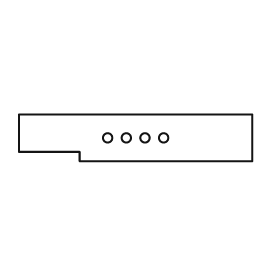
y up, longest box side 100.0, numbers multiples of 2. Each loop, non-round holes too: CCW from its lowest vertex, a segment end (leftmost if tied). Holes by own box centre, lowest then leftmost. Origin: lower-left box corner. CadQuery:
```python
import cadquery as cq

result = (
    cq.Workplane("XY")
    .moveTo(26.0, 0.0)
    .lineTo(100.0, 0.0)
    .lineTo(100.0, 20.0)
    .lineTo(0.0, 20.0)
    .lineTo(0.0, 4.0)
    .lineTo(26.0, 4.0)
    .close()
    .moveTo(38.0, 10.0)
    .circle(2.0)
    .moveTo(46.0, 10.0)
    .circle(2.0)
    .moveTo(54.0, 10.0)
    .circle(2.0)
    .moveTo(62.0, 10.0)
    .circle(2.0)
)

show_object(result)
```